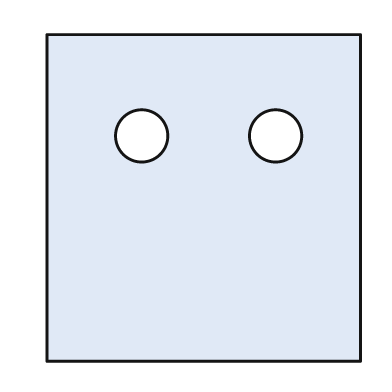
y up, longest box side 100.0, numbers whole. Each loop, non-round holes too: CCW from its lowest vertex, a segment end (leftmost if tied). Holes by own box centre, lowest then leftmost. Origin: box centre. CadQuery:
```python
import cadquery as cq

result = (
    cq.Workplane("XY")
    .moveTo(-48.0, -50.0)
    .lineTo(48.0, -50.0)
    .lineTo(48.0, 50.0)
    .lineTo(-48.0, 50.0)
    .close()
    .moveTo(-19.0, 19.0)
    .circle(8.0)
    .moveTo(22.0, 19.0)
    .circle(8.0)
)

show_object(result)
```